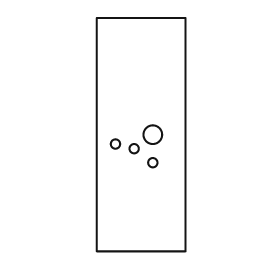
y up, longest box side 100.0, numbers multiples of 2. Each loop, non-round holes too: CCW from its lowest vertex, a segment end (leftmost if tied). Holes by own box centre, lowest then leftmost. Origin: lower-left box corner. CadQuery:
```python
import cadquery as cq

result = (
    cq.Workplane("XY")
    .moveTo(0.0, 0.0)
    .lineTo(38.0, 0.0)
    .lineTo(38.0, 100.0)
    .lineTo(0.0, 100.0)
    .close()
    .moveTo(24.0, 38.0)
    .circle(2.0)
    .moveTo(16.0, 44.0)
    .circle(2.0)
    .moveTo(8.0, 46.0)
    .circle(2.0)
    .moveTo(24.0, 50.0)
    .circle(4.0)
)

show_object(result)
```